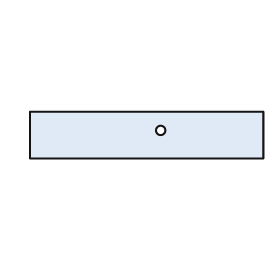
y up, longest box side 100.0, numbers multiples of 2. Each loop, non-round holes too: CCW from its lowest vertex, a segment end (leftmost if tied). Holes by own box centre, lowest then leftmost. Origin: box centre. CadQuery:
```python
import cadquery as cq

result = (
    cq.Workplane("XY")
    .moveTo(-50.0, -10.0)
    .lineTo(50.0, -10.0)
    .lineTo(50.0, 10.0)
    .lineTo(-50.0, 10.0)
    .close()
    .moveTo(6.0, 2.0)
    .circle(2.0)
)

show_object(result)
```